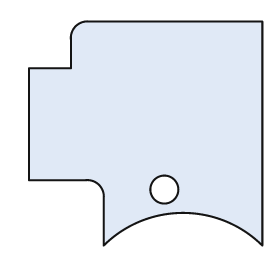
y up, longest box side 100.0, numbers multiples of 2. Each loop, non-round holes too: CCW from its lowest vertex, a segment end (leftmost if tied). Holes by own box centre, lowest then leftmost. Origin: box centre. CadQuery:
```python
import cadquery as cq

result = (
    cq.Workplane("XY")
    .moveTo(-18.0, -48.0)
    .threePointArc((16.0, -34.0), (50.0, -48.0))
    .lineTo(50.0, 48.0)
    .lineTo(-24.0, 48.0)
    .threePointArc((-30.0, 46.0), (-32.0, 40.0))
    .lineTo(-32.0, 28.0)
    .lineTo(-50.0, 28.0)
    .lineTo(-50.0, -20.0)
    .lineTo(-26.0, -20.0)
    .threePointArc((-20.0, -22.0), (-18.0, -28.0))
    .close()
    .moveTo(8.0, -24.0)
    .circle(6.0)
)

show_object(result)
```